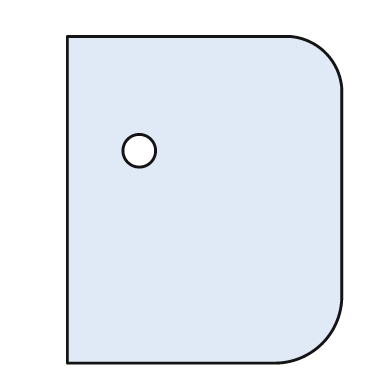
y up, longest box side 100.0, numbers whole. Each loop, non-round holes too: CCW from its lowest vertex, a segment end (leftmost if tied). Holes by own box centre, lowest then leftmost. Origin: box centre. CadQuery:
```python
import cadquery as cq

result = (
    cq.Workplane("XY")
    .moveTo(-42.0, -50.0)
    .lineTo(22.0, -50.0)
    .threePointArc((36.0, -44.0), (42.0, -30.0))
    .lineTo(42.0, 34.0)
    .threePointArc((37.0, 45.0), (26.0, 50.0))
    .lineTo(-42.0, 50.0)
    .close()
    .moveTo(-20.0, 15.0)
    .circle(5.0)
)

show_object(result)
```